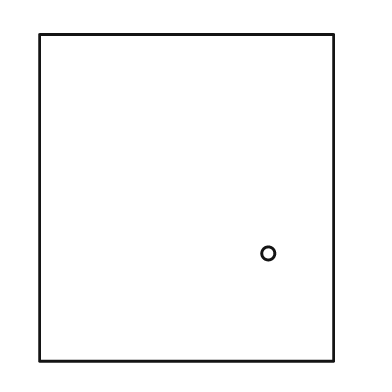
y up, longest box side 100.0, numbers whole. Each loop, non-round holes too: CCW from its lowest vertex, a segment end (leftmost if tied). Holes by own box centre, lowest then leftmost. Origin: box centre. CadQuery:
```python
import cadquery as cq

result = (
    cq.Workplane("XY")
    .moveTo(-45.0, -50.0)
    .lineTo(45.0, -50.0)
    .lineTo(45.0, 50.0)
    .lineTo(-45.0, 50.0)
    .close()
    .moveTo(25.0, -17.0)
    .circle(2.0)
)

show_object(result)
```